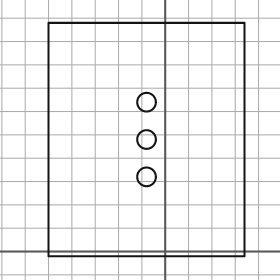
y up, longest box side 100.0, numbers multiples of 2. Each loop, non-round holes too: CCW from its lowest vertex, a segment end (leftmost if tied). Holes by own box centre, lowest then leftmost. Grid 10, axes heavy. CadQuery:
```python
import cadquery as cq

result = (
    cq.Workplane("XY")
    .moveTo(-50.0, -2.0)
    .lineTo(34.0, -2.0)
    .lineTo(34.0, 98.0)
    .lineTo(-50.0, 98.0)
    .close()
    .moveTo(-8.0, 32.0)
    .circle(4.0)
    .moveTo(-8.0, 48.0)
    .circle(4.0)
    .moveTo(-8.0, 64.0)
    .circle(4.0)
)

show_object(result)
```